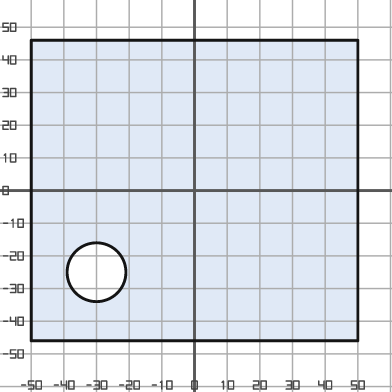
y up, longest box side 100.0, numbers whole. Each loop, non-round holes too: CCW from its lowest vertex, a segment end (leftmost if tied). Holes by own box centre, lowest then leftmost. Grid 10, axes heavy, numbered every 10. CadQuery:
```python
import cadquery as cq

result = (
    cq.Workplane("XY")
    .moveTo(-50.0, -46.0)
    .lineTo(50.0, -46.0)
    .lineTo(50.0, 46.0)
    .lineTo(-50.0, 46.0)
    .close()
    .moveTo(-30.0, -25.0)
    .circle(9.0)
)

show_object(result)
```